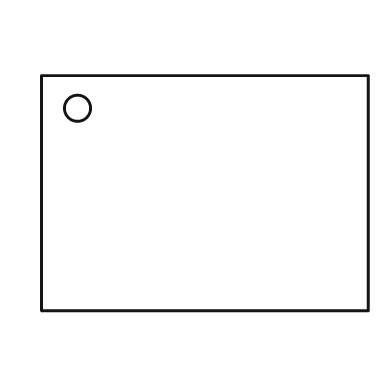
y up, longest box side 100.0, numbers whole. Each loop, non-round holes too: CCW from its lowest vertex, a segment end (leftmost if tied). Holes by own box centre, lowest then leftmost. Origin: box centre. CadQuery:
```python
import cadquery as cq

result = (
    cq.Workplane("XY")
    .moveTo(-50.0, -36.0)
    .lineTo(50.0, -36.0)
    .lineTo(50.0, 36.0)
    .lineTo(-50.0, 36.0)
    .close()
    .moveTo(-39.0, 26.0)
    .circle(4.0)
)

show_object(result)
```